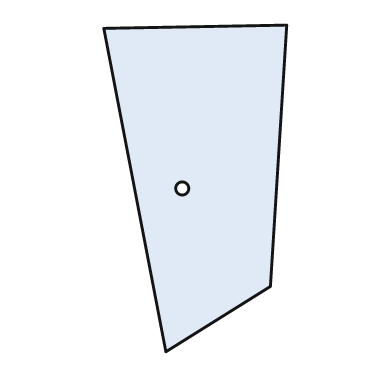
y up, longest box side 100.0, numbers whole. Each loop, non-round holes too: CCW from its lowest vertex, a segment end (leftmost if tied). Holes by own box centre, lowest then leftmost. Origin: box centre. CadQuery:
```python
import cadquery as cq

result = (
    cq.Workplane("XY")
    .moveTo(-9.0, -50.0)
    .lineTo(23.0, -30.0)
    .lineTo(28.0, 50.0)
    .lineTo(-28.0, 49.0)
    .close()
    .moveTo(-4.0, 0.0)
    .circle(2.0)
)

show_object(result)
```